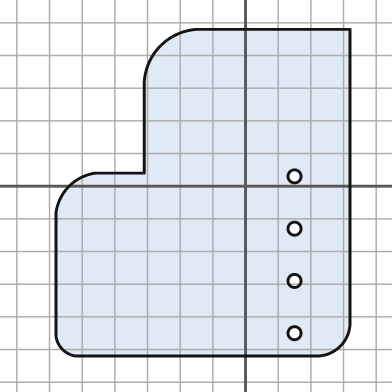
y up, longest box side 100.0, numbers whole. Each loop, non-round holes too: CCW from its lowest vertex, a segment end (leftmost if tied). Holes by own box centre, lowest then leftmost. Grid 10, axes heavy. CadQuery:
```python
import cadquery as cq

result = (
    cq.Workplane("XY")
    .moveTo(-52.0, -52.0)
    .lineTo(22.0, -52.0)
    .threePointArc((29.0, -49.0), (32.0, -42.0))
    .lineTo(32.0, 48.0)
    .lineTo(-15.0, 48.0)
    .threePointArc((-26.0, 43.0), (-31.0, 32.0))
    .lineTo(-31.0, 4.0)
    .lineTo(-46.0, 4.0)
    .threePointArc((-54.0, 0.0), (-58.0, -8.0))
    .lineTo(-58.0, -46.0)
    .threePointArc((-56.0, -50.0), (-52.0, -52.0))
    .close()
    .moveTo(15.0, -45.0)
    .circle(2.0)
    .moveTo(15.0, -29.0)
    .circle(2.0)
    .moveTo(15.0, -13.0)
    .circle(2.0)
    .moveTo(15.0, 3.0)
    .circle(2.0)
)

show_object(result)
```